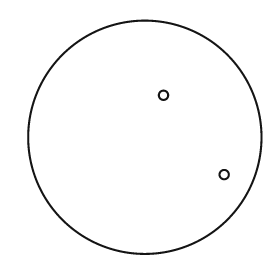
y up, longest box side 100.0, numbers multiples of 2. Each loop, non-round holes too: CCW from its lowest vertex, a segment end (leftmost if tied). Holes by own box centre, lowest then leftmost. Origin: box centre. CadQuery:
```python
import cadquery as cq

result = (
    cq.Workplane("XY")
    .moveTo(0.0, 0.0)
    .circle(50.0)
    .moveTo(34.0, -16.0)
    .circle(2.0)
    .moveTo(8.0, 18.0)
    .circle(2.0)
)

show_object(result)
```